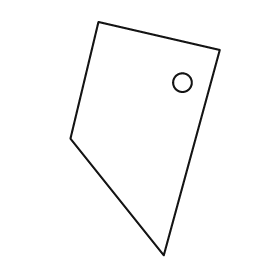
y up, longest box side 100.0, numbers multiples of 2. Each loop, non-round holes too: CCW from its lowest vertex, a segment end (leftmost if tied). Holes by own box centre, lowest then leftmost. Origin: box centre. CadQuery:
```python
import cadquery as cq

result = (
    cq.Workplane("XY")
    .moveTo(8.0, -50.0)
    .lineTo(32.0, 38.0)
    .lineTo(-20.0, 50.0)
    .lineTo(-32.0, 0.0)
    .close()
    .moveTo(16.0, 24.0)
    .circle(4.0)
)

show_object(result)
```